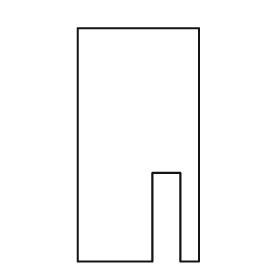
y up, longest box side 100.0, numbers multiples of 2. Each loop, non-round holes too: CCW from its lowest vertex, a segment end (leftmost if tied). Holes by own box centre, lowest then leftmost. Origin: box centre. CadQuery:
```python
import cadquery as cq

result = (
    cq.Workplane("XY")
    .moveTo(-26.0, -50.0)
    .lineTo(6.0, -50.0)
    .lineTo(6.0, -12.0)
    .lineTo(18.0, -12.0)
    .lineTo(18.0, -50.0)
    .lineTo(26.0, -50.0)
    .lineTo(26.0, 50.0)
    .lineTo(-26.0, 50.0)
    .close()
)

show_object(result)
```